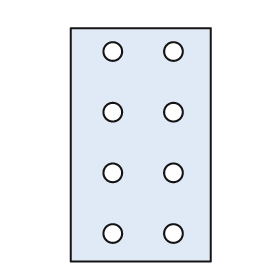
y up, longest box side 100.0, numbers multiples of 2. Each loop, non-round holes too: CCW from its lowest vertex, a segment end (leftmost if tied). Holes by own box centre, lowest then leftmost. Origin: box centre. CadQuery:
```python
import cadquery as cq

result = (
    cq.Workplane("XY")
    .moveTo(-30.0, -50.0)
    .lineTo(30.0, -50.0)
    .lineTo(30.0, 50.0)
    .lineTo(-30.0, 50.0)
    .close()
    .moveTo(-12.0, -38.0)
    .circle(4.0)
    .moveTo(14.0, -38.0)
    .circle(4.0)
    .moveTo(-12.0, -12.0)
    .circle(4.0)
    .moveTo(14.0, -12.0)
    .circle(4.0)
    .moveTo(-12.0, 14.0)
    .circle(4.0)
    .moveTo(14.0, 14.0)
    .circle(4.0)
    .moveTo(-12.0, 40.0)
    .circle(4.0)
    .moveTo(14.0, 40.0)
    .circle(4.0)
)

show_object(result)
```